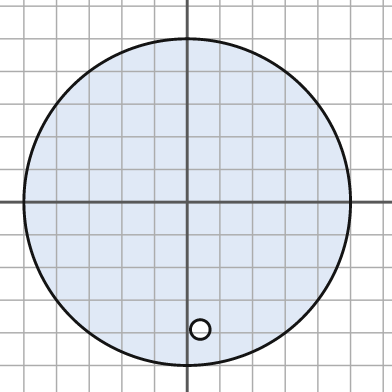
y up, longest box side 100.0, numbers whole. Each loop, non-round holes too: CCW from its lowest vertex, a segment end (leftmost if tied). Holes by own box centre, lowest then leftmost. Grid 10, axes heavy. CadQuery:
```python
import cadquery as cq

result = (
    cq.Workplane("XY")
    .moveTo(0.0, 0.0)
    .circle(50.0)
    .moveTo(4.0, -39.0)
    .circle(3.0)
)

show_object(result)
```